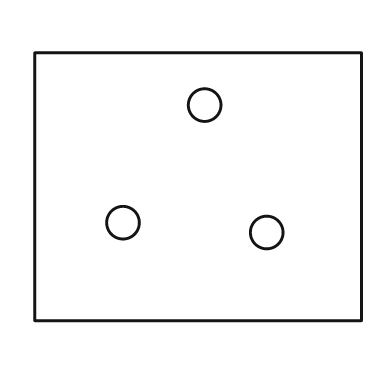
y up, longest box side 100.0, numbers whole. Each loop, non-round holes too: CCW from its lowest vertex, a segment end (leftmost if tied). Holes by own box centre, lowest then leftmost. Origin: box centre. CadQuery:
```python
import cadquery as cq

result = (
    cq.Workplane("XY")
    .moveTo(-50.0, -41.0)
    .lineTo(50.0, -41.0)
    .lineTo(50.0, 41.0)
    .lineTo(-50.0, 41.0)
    .close()
    .moveTo(21.0, -14.0)
    .circle(5.0)
    .moveTo(-23.0, -11.0)
    .circle(5.0)
    .moveTo(2.0, 25.0)
    .circle(5.0)
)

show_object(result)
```